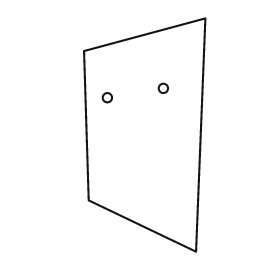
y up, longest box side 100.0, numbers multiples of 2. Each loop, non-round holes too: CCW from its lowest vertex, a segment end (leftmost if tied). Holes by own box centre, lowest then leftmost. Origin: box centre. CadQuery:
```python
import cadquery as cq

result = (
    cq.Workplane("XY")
    .moveTo(22.0, -50.0)
    .lineTo(26.0, 50.0)
    .lineTo(-26.0, 36.0)
    .lineTo(-24.0, -28.0)
    .close()
    .moveTo(-16.0, 16.0)
    .circle(2.0)
    .moveTo(8.0, 20.0)
    .circle(2.0)
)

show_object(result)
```